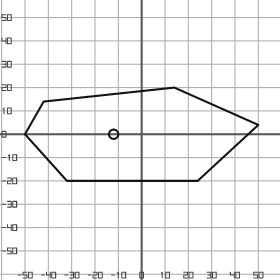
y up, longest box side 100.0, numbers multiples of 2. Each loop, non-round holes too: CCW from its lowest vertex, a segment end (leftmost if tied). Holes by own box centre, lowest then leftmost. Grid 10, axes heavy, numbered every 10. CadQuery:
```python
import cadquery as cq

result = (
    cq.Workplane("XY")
    .moveTo(-32.0, -20.0)
    .lineTo(24.0, -20.0)
    .lineTo(50.0, 4.0)
    .lineTo(14.0, 20.0)
    .lineTo(-42.0, 14.0)
    .lineTo(-50.0, 0.0)
    .close()
    .moveTo(-12.0, 0.0)
    .circle(2.0)
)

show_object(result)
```